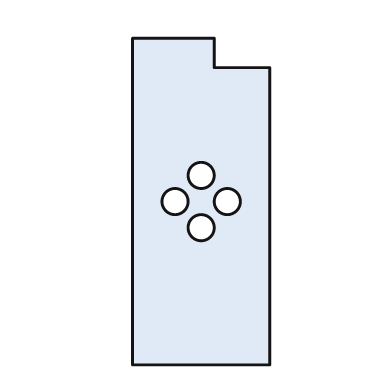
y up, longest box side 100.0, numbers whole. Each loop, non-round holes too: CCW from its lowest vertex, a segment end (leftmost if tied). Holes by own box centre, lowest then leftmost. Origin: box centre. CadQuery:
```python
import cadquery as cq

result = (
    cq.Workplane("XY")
    .moveTo(-21.0, -50.0)
    .lineTo(21.0, -50.0)
    .lineTo(21.0, 41.0)
    .lineTo(4.0, 41.0)
    .lineTo(4.0, 50.0)
    .lineTo(-21.0, 50.0)
    .close()
    .moveTo(0.0, -8.0)
    .circle(4.0)
    .moveTo(-8.0, 0.0)
    .circle(4.0)
    .moveTo(8.0, 0.0)
    .circle(4.0)
    .moveTo(0.0, 8.0)
    .circle(4.0)
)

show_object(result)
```